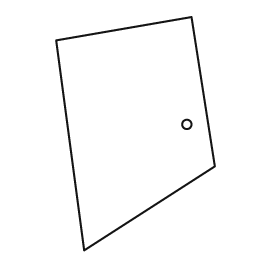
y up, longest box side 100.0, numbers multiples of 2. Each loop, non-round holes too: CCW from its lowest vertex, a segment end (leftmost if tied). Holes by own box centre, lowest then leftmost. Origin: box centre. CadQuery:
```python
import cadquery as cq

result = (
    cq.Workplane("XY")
    .moveTo(-22.0, -50.0)
    .lineTo(34.0, -14.0)
    .lineTo(24.0, 50.0)
    .lineTo(-34.0, 40.0)
    .close()
    .moveTo(22.0, 4.0)
    .circle(2.0)
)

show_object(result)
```